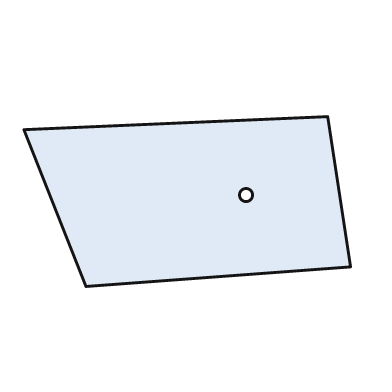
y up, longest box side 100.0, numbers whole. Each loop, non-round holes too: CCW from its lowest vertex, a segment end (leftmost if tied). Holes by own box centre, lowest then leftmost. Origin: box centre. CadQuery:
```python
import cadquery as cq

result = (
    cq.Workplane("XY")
    .moveTo(-31.0, -26.0)
    .lineTo(50.0, -20.0)
    .lineTo(43.0, 26.0)
    .lineTo(-50.0, 22.0)
    .close()
    .moveTo(18.0, 2.0)
    .circle(2.0)
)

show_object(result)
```